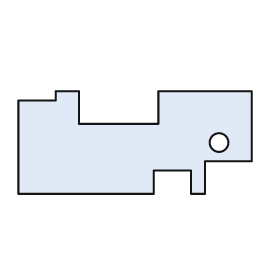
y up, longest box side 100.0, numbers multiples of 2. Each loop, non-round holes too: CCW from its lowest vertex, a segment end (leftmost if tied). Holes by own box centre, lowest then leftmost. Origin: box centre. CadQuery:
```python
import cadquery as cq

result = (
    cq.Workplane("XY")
    .moveTo(-50.0, -22.0)
    .lineTo(8.0, -22.0)
    .lineTo(8.0, -12.0)
    .lineTo(24.0, -12.0)
    .lineTo(24.0, -22.0)
    .lineTo(30.0, -22.0)
    .lineTo(30.0, -8.0)
    .lineTo(50.0, -8.0)
    .lineTo(50.0, 22.0)
    .lineTo(10.0, 22.0)
    .lineTo(10.0, 8.0)
    .lineTo(-24.0, 8.0)
    .lineTo(-24.0, 22.0)
    .lineTo(-34.0, 22.0)
    .lineTo(-34.0, 18.0)
    .lineTo(-50.0, 18.0)
    .close()
    .moveTo(36.0, 0.0)
    .circle(4.0)
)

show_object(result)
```